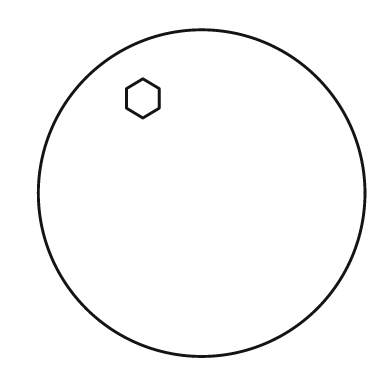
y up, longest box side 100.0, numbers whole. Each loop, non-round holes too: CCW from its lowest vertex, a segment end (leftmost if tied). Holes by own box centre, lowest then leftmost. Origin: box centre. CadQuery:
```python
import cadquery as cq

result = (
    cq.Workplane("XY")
    .moveTo(0.0, 0.0)
    .circle(50.0)
    .moveTo(-18.0, 23.0)
    .lineTo(-13.0, 26.0)
    .lineTo(-13.0, 32.0)
    .lineTo(-18.0, 35.0)
    .lineTo(-23.0, 32.0)
    .lineTo(-23.0, 26.0)
    .close()
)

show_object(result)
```